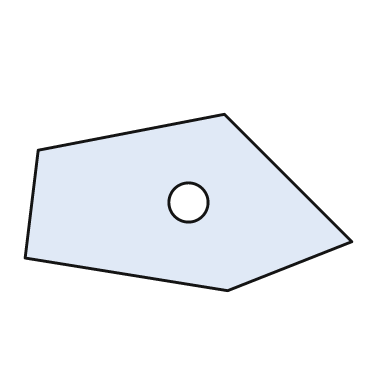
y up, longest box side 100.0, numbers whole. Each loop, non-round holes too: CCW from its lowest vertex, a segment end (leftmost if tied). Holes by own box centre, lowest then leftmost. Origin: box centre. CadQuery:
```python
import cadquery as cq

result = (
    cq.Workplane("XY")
    .moveTo(12.0, -27.0)
    .lineTo(50.0, -12.0)
    .lineTo(11.0, 27.0)
    .lineTo(-46.0, 16.0)
    .lineTo(-50.0, -17.0)
    .close()
    .moveTo(0.0, 0.0)
    .circle(6.0)
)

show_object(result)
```